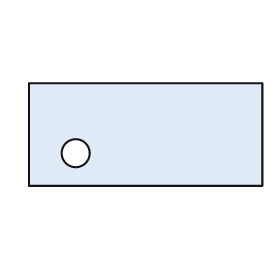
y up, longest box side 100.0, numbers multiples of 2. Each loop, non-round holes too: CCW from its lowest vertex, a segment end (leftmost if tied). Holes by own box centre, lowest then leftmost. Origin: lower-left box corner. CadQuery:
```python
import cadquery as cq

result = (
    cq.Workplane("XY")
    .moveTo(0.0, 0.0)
    .lineTo(100.0, 0.0)
    .lineTo(100.0, 44.0)
    .lineTo(0.0, 44.0)
    .close()
    .moveTo(20.0, 14.0)
    .circle(6.0)
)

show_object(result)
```